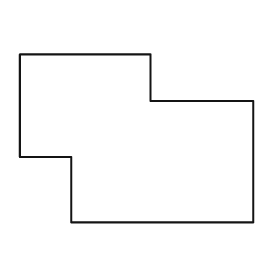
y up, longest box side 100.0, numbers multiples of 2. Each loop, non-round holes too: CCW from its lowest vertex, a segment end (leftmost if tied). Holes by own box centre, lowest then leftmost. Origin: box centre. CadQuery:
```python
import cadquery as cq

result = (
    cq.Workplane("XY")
    .moveTo(-28.0, -36.0)
    .lineTo(50.0, -36.0)
    .lineTo(50.0, 16.0)
    .lineTo(6.0, 16.0)
    .lineTo(6.0, 36.0)
    .lineTo(-50.0, 36.0)
    .lineTo(-50.0, -8.0)
    .lineTo(-28.0, -8.0)
    .close()
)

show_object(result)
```